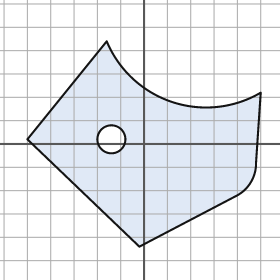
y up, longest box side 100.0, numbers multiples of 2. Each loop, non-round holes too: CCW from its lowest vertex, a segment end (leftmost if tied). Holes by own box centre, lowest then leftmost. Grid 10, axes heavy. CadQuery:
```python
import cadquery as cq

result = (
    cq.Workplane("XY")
    .moveTo(-2.0, -44.0)
    .lineTo(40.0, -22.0)
    .threePointArc((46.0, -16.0), (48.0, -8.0))
    .lineTo(50.0, 22.0)
    .threePointArc((12.0, 18.0), (-16.0, 44.0))
    .lineTo(-50.0, 2.0)
    .close()
    .moveTo(-14.0, 2.0)
    .circle(6.0)
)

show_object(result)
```